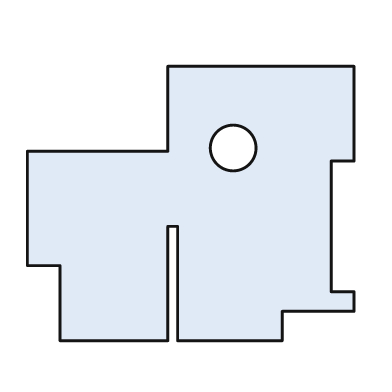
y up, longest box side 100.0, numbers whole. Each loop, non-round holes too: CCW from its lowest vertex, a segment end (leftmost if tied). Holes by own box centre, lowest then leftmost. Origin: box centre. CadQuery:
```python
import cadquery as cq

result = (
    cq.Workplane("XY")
    .moveTo(-40.0, -42.0)
    .lineTo(-7.0, -42.0)
    .lineTo(-7.0, -7.0)
    .lineTo(-4.0, -7.0)
    .lineTo(-4.0, -42.0)
    .lineTo(28.0, -42.0)
    .lineTo(28.0, -33.0)
    .lineTo(50.0, -33.0)
    .lineTo(50.0, -27.0)
    .lineTo(43.0, -27.0)
    .lineTo(43.0, 13.0)
    .lineTo(50.0, 13.0)
    .lineTo(50.0, 42.0)
    .lineTo(-7.0, 42.0)
    .lineTo(-7.0, 16.0)
    .lineTo(-50.0, 16.0)
    .lineTo(-50.0, -19.0)
    .lineTo(-40.0, -19.0)
    .close()
    .moveTo(13.0, 17.0)
    .circle(7.0)
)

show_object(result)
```